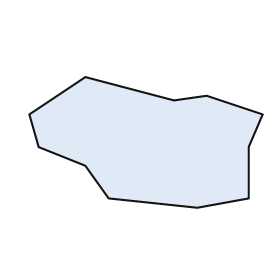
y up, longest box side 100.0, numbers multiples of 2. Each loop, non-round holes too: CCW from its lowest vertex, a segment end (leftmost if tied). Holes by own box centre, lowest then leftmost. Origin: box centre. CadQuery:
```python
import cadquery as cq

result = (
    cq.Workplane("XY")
    .moveTo(22.0, -28.0)
    .lineTo(44.0, -24.0)
    .lineTo(44.0, -2.0)
    .lineTo(50.0, 12.0)
    .lineTo(26.0, 20.0)
    .lineTo(12.0, 18.0)
    .lineTo(-26.0, 28.0)
    .lineTo(-50.0, 12.0)
    .lineTo(-46.0, -2.0)
    .lineTo(-26.0, -10.0)
    .lineTo(-16.0, -24.0)
    .close()
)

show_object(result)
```